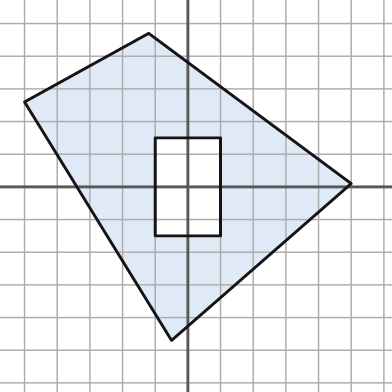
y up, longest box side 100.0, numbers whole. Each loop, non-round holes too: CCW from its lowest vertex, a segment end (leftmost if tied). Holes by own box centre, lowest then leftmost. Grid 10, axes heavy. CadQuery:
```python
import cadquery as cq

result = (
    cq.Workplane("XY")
    .moveTo(-5.0, -47.0)
    .lineTo(50.0, 1.0)
    .lineTo(-12.0, 47.0)
    .lineTo(-50.0, 26.0)
    .close()
    .moveTo(-10.0, -15.0)
    .lineTo(10.0, -15.0)
    .lineTo(10.0, 15.0)
    .lineTo(-10.0, 15.0)
    .close()
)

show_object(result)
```